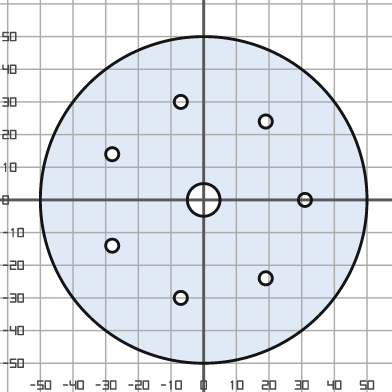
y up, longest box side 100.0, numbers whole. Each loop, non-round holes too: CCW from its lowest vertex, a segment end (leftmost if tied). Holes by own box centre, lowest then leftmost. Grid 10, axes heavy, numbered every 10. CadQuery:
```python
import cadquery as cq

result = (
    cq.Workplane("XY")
    .moveTo(0.0, 0.0)
    .circle(50.0)
    .moveTo(-7.0, -30.0)
    .circle(2.0)
    .moveTo(19.0, -24.0)
    .circle(2.0)
    .moveTo(-28.0, -14.0)
    .circle(2.0)
    .moveTo(0.0, 0.0)
    .circle(5.0)
    .moveTo(31.0, 0.0)
    .circle(2.0)
    .moveTo(-28.0, 14.0)
    .circle(2.0)
    .moveTo(19.0, 24.0)
    .circle(2.0)
    .moveTo(-7.0, 30.0)
    .circle(2.0)
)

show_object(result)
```